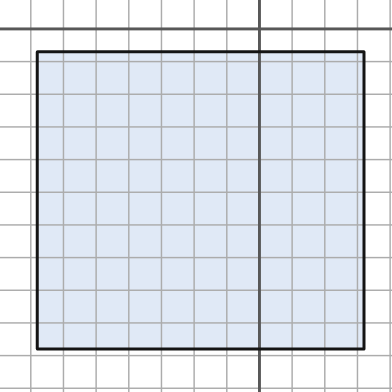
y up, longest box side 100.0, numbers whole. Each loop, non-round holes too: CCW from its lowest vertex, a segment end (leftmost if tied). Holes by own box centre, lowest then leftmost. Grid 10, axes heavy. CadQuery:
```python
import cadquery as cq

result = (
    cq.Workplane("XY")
    .moveTo(-68.0, -98.0)
    .lineTo(32.0, -98.0)
    .lineTo(32.0, -7.0)
    .lineTo(-68.0, -7.0)
    .close()
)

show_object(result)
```